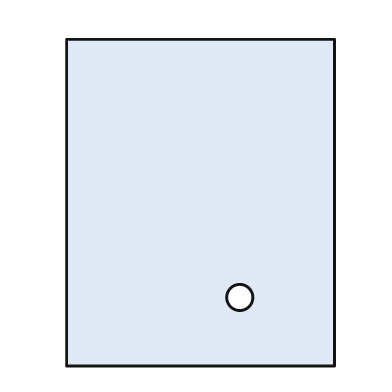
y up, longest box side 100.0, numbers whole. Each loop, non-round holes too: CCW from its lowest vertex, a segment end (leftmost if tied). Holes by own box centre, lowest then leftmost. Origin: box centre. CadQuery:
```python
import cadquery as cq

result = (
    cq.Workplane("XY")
    .moveTo(-41.0, -50.0)
    .lineTo(41.0, -50.0)
    .lineTo(41.0, 50.0)
    .lineTo(-41.0, 50.0)
    .close()
    .moveTo(12.0, -29.0)
    .circle(4.0)
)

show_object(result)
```